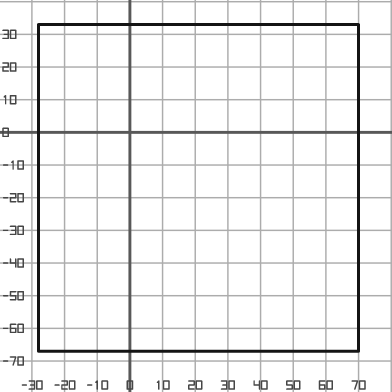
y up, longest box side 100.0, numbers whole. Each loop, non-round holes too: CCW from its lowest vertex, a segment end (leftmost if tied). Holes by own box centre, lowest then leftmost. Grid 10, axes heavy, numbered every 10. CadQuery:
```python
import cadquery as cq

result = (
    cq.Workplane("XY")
    .moveTo(-28.0, -67.0)
    .lineTo(70.0, -67.0)
    .lineTo(70.0, 33.0)
    .lineTo(-28.0, 33.0)
    .close()
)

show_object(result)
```